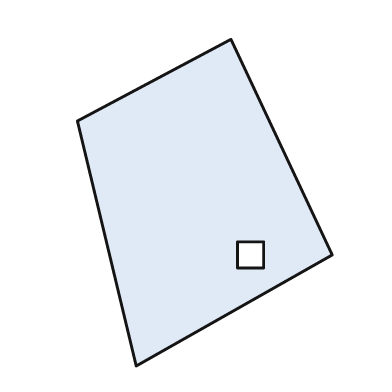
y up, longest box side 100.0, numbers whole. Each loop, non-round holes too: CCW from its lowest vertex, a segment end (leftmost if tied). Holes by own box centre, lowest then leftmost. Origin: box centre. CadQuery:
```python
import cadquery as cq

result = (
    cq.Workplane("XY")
    .moveTo(-21.0, -50.0)
    .lineTo(39.0, -16.0)
    .lineTo(8.0, 50.0)
    .lineTo(-39.0, 25.0)
    .close()
    .moveTo(10.0, -20.0)
    .lineTo(18.0, -20.0)
    .lineTo(18.0, -12.0)
    .lineTo(10.0, -12.0)
    .close()
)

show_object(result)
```